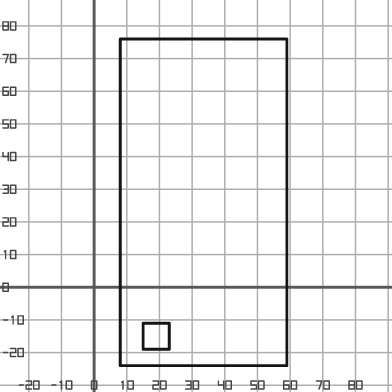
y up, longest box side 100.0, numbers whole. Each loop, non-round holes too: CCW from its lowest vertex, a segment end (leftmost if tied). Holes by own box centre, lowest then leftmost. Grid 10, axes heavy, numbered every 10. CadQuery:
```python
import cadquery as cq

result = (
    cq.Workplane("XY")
    .moveTo(8.0, -24.0)
    .lineTo(59.0, -24.0)
    .lineTo(59.0, 76.0)
    .lineTo(8.0, 76.0)
    .close()
    .moveTo(15.0, -19.0)
    .lineTo(23.0, -19.0)
    .lineTo(23.0, -11.0)
    .lineTo(15.0, -11.0)
    .close()
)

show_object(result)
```